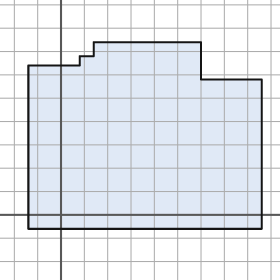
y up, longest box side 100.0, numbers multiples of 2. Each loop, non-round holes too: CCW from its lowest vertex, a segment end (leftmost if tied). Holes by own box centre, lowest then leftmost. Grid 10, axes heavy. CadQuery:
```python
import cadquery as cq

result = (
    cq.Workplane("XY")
    .moveTo(-14.0, -6.0)
    .lineTo(86.0, -6.0)
    .lineTo(86.0, 58.0)
    .lineTo(60.0, 58.0)
    .lineTo(60.0, 74.0)
    .lineTo(14.0, 74.0)
    .lineTo(14.0, 68.0)
    .lineTo(8.0, 68.0)
    .lineTo(8.0, 64.0)
    .lineTo(-14.0, 64.0)
    .close()
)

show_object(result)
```